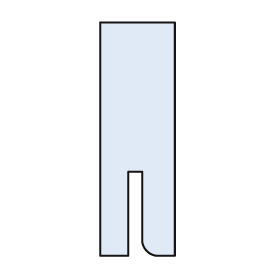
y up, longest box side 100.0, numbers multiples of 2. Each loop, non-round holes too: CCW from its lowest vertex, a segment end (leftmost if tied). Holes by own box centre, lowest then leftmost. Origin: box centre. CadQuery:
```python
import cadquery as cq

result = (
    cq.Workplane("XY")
    .moveTo(-16.0, -50.0)
    .lineTo(-4.0, -50.0)
    .lineTo(-4.0, -14.0)
    .lineTo(2.0, -14.0)
    .lineTo(2.0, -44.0)
    .threePointArc((4.0, -48.0), (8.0, -50.0))
    .lineTo(16.0, -50.0)
    .lineTo(16.0, 50.0)
    .lineTo(-16.0, 50.0)
    .close()
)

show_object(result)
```